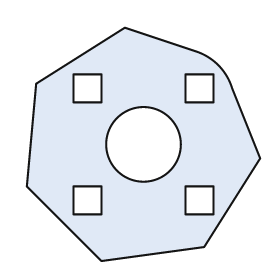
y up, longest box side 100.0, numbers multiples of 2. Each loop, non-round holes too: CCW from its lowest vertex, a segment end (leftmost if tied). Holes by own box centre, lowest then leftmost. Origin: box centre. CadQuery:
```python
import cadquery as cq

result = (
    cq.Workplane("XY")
    .moveTo(-18.0, -50.0)
    .lineTo(26.0, -44.0)
    .lineTo(50.0, -6.0)
    .lineTo(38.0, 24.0)
    .threePointArc((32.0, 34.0), (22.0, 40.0))
    .lineTo(-8.0, 50.0)
    .lineTo(-46.0, 26.0)
    .lineTo(-50.0, -18.0)
    .close()
    .moveTo(-30.0, -30.0)
    .lineTo(-18.0, -30.0)
    .lineTo(-18.0, -18.0)
    .lineTo(-30.0, -18.0)
    .close()
    .moveTo(18.0, -30.0)
    .lineTo(30.0, -30.0)
    .lineTo(30.0, -18.0)
    .lineTo(18.0, -18.0)
    .close()
    .moveTo(0.0, 0.0)
    .circle(16.0)
    .moveTo(-30.0, 18.0)
    .lineTo(-18.0, 18.0)
    .lineTo(-18.0, 30.0)
    .lineTo(-30.0, 30.0)
    .close()
    .moveTo(18.0, 18.0)
    .lineTo(30.0, 18.0)
    .lineTo(30.0, 30.0)
    .lineTo(18.0, 30.0)
    .close()
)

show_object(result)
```